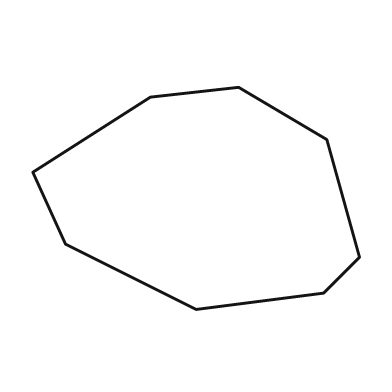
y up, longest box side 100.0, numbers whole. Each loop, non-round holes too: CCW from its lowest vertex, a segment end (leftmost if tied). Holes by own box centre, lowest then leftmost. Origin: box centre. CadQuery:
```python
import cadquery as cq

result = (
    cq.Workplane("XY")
    .moveTo(0.0, -34.0)
    .lineTo(39.0, -29.0)
    .lineTo(50.0, -18.0)
    .lineTo(40.0, 18.0)
    .lineTo(13.0, 34.0)
    .lineTo(-14.0, 31.0)
    .lineTo(-50.0, 8.0)
    .lineTo(-40.0, -14.0)
    .close()
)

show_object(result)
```